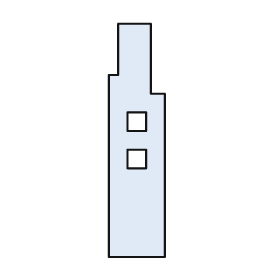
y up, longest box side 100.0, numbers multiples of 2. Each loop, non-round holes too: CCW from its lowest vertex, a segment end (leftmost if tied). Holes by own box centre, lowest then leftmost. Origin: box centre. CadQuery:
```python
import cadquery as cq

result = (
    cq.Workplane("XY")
    .moveTo(-12.0, -50.0)
    .lineTo(12.0, -50.0)
    .lineTo(12.0, 20.0)
    .lineTo(6.0, 20.0)
    .lineTo(6.0, 50.0)
    .lineTo(-8.0, 50.0)
    .lineTo(-8.0, 28.0)
    .lineTo(-12.0, 28.0)
    .close()
    .moveTo(-4.0, -12.0)
    .lineTo(4.0, -12.0)
    .lineTo(4.0, -4.0)
    .lineTo(-4.0, -4.0)
    .close()
    .moveTo(-4.0, 4.0)
    .lineTo(4.0, 4.0)
    .lineTo(4.0, 12.0)
    .lineTo(-4.0, 12.0)
    .close()
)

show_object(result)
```